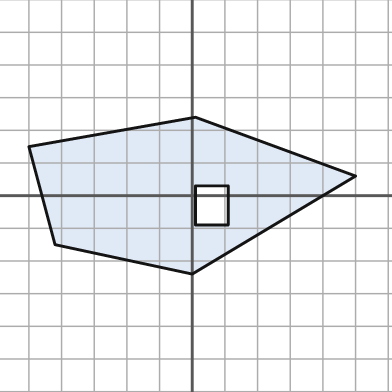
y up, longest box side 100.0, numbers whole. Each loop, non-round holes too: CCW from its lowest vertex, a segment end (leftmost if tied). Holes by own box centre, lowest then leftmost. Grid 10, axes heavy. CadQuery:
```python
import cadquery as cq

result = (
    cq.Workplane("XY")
    .moveTo(0.0, -24.0)
    .lineTo(50.0, 6.0)
    .lineTo(1.0, 24.0)
    .lineTo(-50.0, 15.0)
    .lineTo(-42.0, -15.0)
    .close()
    .moveTo(1.0, -9.0)
    .lineTo(11.0, -9.0)
    .lineTo(11.0, 3.0)
    .lineTo(1.0, 3.0)
    .close()
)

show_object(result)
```